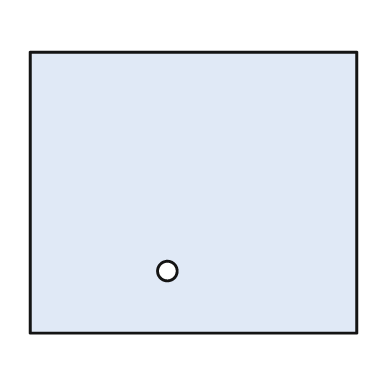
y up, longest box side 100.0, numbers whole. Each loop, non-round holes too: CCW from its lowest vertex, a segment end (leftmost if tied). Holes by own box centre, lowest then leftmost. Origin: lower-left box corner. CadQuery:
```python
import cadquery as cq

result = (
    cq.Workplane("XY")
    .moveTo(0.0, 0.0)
    .lineTo(100.0, 0.0)
    .lineTo(100.0, 86.0)
    .lineTo(0.0, 86.0)
    .close()
    .moveTo(42.0, 19.0)
    .circle(3.0)
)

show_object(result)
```